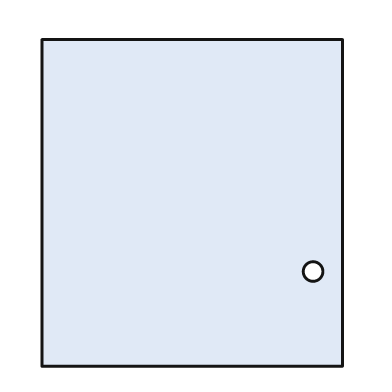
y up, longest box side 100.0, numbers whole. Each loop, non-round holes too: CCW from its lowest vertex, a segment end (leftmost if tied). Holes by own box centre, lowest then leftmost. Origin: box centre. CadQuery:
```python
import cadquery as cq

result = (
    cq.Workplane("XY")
    .moveTo(-46.0, -50.0)
    .lineTo(46.0, -50.0)
    .lineTo(46.0, 50.0)
    .lineTo(-46.0, 50.0)
    .close()
    .moveTo(37.0, -21.0)
    .circle(3.0)
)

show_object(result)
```